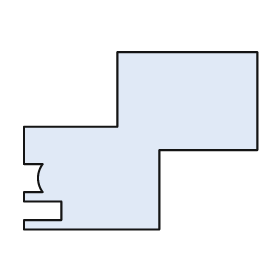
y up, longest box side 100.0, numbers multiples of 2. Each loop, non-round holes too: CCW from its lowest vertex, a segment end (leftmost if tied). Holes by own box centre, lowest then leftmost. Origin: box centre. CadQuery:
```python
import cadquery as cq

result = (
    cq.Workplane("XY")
    .moveTo(-50.0, -38.0)
    .lineTo(8.0, -38.0)
    .lineTo(8.0, -4.0)
    .lineTo(50.0, -4.0)
    .lineTo(50.0, 38.0)
    .lineTo(-10.0, 38.0)
    .lineTo(-10.0, 6.0)
    .lineTo(-50.0, 6.0)
    .lineTo(-50.0, -10.0)
    .lineTo(-42.0, -10.0)
    .threePointArc((-44.0, -16.0), (-42.0, -22.0))
    .lineTo(-50.0, -22.0)
    .lineTo(-50.0, -26.0)
    .lineTo(-34.0, -26.0)
    .lineTo(-34.0, -34.0)
    .lineTo(-50.0, -34.0)
    .close()
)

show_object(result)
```